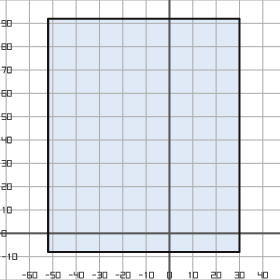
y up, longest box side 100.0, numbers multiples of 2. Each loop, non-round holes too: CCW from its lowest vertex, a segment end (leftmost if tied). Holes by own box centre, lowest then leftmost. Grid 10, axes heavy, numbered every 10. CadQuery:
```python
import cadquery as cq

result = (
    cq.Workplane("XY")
    .moveTo(-52.0, -8.0)
    .lineTo(30.0, -8.0)
    .lineTo(30.0, 92.0)
    .lineTo(-52.0, 92.0)
    .close()
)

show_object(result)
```